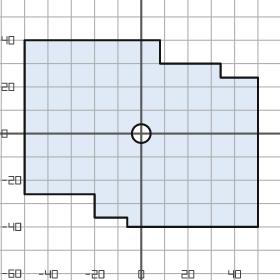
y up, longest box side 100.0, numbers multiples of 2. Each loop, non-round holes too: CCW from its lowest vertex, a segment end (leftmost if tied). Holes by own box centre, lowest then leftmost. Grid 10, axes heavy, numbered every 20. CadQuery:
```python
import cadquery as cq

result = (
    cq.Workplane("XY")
    .moveTo(-6.0, -40.0)
    .lineTo(50.0, -40.0)
    .lineTo(50.0, 24.0)
    .lineTo(34.0, 24.0)
    .lineTo(34.0, 30.0)
    .lineTo(8.0, 30.0)
    .lineTo(8.0, 40.0)
    .lineTo(-50.0, 40.0)
    .lineTo(-50.0, -26.0)
    .lineTo(-20.0, -26.0)
    .lineTo(-20.0, -36.0)
    .lineTo(-6.0, -36.0)
    .close()
    .moveTo(0.0, 0.0)
    .circle(4.0)
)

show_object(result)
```